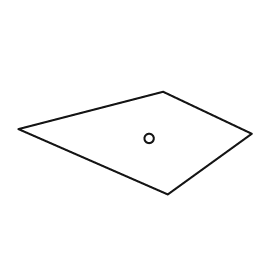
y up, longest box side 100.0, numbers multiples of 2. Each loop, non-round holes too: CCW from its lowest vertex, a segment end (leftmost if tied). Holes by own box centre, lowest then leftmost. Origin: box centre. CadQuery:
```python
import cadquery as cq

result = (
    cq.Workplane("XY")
    .moveTo(14.0, -22.0)
    .lineTo(50.0, 4.0)
    .lineTo(12.0, 22.0)
    .lineTo(-50.0, 6.0)
    .close()
    .moveTo(6.0, 2.0)
    .circle(2.0)
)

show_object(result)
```